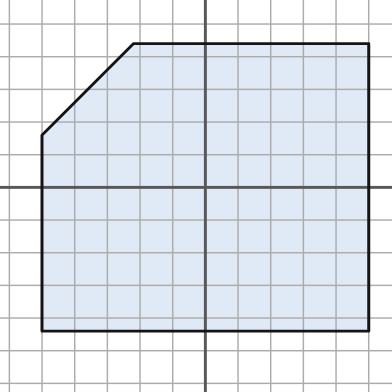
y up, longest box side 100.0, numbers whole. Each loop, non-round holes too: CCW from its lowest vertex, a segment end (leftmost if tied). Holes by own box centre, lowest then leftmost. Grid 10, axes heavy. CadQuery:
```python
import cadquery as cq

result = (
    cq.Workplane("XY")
    .moveTo(-50.0, -44.0)
    .lineTo(50.0, -44.0)
    .lineTo(50.0, 44.0)
    .lineTo(-22.0, 44.0)
    .lineTo(-50.0, 16.0)
    .close()
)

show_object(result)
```